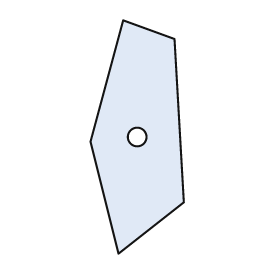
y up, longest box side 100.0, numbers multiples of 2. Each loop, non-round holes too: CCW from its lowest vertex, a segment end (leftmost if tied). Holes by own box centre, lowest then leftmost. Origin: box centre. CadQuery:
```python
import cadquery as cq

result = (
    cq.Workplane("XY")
    .moveTo(-8.0, -50.0)
    .lineTo(20.0, -28.0)
    .lineTo(16.0, 42.0)
    .lineTo(-6.0, 50.0)
    .lineTo(-20.0, -2.0)
    .close()
    .moveTo(0.0, 0.0)
    .circle(4.0)
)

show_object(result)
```